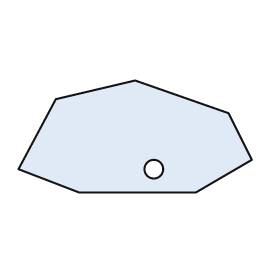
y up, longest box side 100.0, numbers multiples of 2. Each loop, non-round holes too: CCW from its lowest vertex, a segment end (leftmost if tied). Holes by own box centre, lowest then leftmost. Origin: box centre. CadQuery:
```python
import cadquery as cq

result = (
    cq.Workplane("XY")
    .moveTo(-24.0, -24.0)
    .lineTo(26.0, -24.0)
    .lineTo(50.0, -10.0)
    .lineTo(40.0, 10.0)
    .lineTo(0.0, 24.0)
    .lineTo(-34.0, 16.0)
    .lineTo(-50.0, -14.0)
    .close()
    .moveTo(8.0, -14.0)
    .circle(4.0)
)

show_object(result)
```